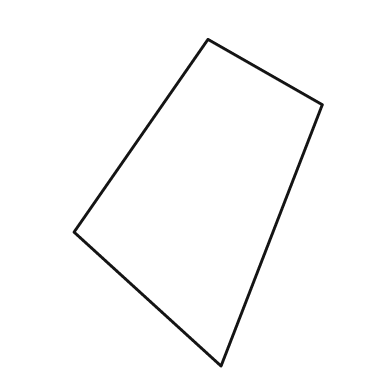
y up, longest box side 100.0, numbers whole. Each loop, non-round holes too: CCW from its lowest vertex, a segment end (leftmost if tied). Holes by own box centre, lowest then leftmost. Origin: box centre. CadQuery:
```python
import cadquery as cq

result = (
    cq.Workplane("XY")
    .moveTo(7.0, -50.0)
    .lineTo(38.0, 30.0)
    .lineTo(3.0, 50.0)
    .lineTo(-38.0, -9.0)
    .close()
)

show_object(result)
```